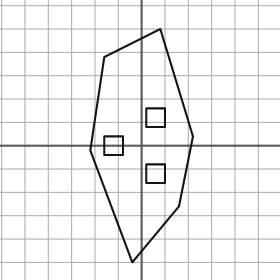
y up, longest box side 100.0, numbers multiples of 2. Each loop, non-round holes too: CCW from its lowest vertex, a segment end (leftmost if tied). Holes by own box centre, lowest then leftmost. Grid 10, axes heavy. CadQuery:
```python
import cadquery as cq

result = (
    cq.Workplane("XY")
    .moveTo(-4.0, -50.0)
    .lineTo(16.0, -26.0)
    .lineTo(22.0, 4.0)
    .lineTo(8.0, 50.0)
    .lineTo(-16.0, 38.0)
    .lineTo(-22.0, -2.0)
    .close()
    .moveTo(2.0, -16.0)
    .lineTo(10.0, -16.0)
    .lineTo(10.0, -8.0)
    .lineTo(2.0, -8.0)
    .close()
    .moveTo(-16.0, -4.0)
    .lineTo(-8.0, -4.0)
    .lineTo(-8.0, 4.0)
    .lineTo(-16.0, 4.0)
    .close()
    .moveTo(2.0, 8.0)
    .lineTo(10.0, 8.0)
    .lineTo(10.0, 16.0)
    .lineTo(2.0, 16.0)
    .close()
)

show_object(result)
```